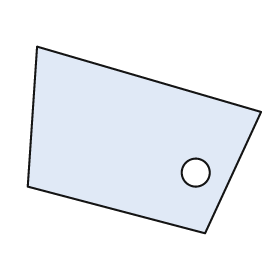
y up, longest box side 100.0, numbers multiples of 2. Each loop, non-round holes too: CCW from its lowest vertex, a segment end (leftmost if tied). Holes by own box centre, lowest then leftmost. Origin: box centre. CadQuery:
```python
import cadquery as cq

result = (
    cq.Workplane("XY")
    .moveTo(26.0, -40.0)
    .lineTo(50.0, 12.0)
    .lineTo(-46.0, 40.0)
    .lineTo(-50.0, -20.0)
    .close()
    .moveTo(22.0, -14.0)
    .circle(6.0)
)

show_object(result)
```